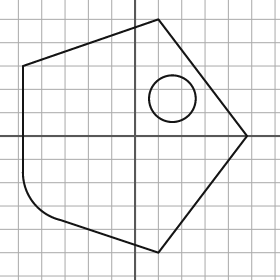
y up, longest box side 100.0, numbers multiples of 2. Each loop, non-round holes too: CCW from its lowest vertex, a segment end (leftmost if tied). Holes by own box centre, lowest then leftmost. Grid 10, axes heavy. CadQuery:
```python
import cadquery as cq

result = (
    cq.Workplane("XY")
    .moveTo(10.0, -50.0)
    .lineTo(48.0, 0.0)
    .lineTo(10.0, 50.0)
    .lineTo(-48.0, 30.0)
    .lineTo(-48.0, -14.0)
    .threePointArc((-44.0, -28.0), (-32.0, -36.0))
    .close()
    .moveTo(16.0, 16.0)
    .circle(10.0)
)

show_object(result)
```